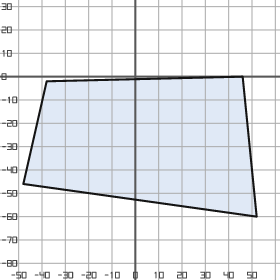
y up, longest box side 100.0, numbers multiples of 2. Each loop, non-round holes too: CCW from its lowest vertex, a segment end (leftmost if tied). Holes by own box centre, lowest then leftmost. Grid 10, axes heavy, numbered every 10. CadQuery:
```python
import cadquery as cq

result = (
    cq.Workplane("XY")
    .moveTo(52.0, -60.0)
    .lineTo(46.0, 0.0)
    .lineTo(-38.0, -2.0)
    .lineTo(-48.0, -46.0)
    .close()
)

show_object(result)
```